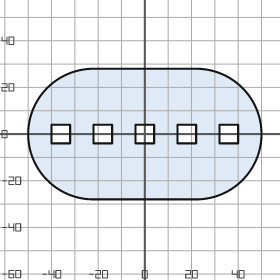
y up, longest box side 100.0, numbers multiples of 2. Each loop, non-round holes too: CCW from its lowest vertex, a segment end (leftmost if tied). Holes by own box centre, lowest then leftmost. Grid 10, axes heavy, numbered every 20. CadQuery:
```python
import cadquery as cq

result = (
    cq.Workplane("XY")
    .moveTo(-22.0, -28.0)
    .lineTo(22.0, -28.0)
    .threePointArc((50.0, 0.0), (22.0, 28.0))
    .lineTo(-22.0, 28.0)
    .threePointArc((-50.0, 0.0), (-22.0, -28.0))
    .close()
    .moveTo(-40.0, -4.0)
    .lineTo(-32.0, -4.0)
    .lineTo(-32.0, 4.0)
    .lineTo(-40.0, 4.0)
    .close()
    .moveTo(-22.0, -4.0)
    .lineTo(-14.0, -4.0)
    .lineTo(-14.0, 4.0)
    .lineTo(-22.0, 4.0)
    .close()
    .moveTo(-4.0, -4.0)
    .lineTo(4.0, -4.0)
    .lineTo(4.0, 4.0)
    .lineTo(-4.0, 4.0)
    .close()
    .moveTo(14.0, -4.0)
    .lineTo(22.0, -4.0)
    .lineTo(22.0, 4.0)
    .lineTo(14.0, 4.0)
    .close()
    .moveTo(32.0, -4.0)
    .lineTo(40.0, -4.0)
    .lineTo(40.0, 4.0)
    .lineTo(32.0, 4.0)
    .close()
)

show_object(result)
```